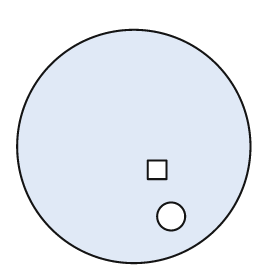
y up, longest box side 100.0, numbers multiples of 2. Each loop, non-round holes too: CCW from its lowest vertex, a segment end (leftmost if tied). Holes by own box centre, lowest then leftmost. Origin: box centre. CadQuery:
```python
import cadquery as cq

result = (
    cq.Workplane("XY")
    .moveTo(0.0, 0.0)
    .circle(50.0)
    .moveTo(16.0, -30.0)
    .circle(6.0)
    .moveTo(6.0, -14.0)
    .lineTo(14.0, -14.0)
    .lineTo(14.0, -6.0)
    .lineTo(6.0, -6.0)
    .close()
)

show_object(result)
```